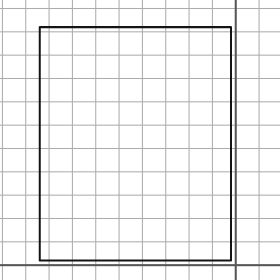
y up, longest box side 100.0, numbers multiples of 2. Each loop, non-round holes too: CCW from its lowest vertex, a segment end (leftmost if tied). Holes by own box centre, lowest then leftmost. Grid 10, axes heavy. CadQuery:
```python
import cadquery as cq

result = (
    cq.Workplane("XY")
    .moveTo(-84.0, 2.0)
    .lineTo(-2.0, 2.0)
    .lineTo(-2.0, 102.0)
    .lineTo(-84.0, 102.0)
    .close()
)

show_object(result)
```